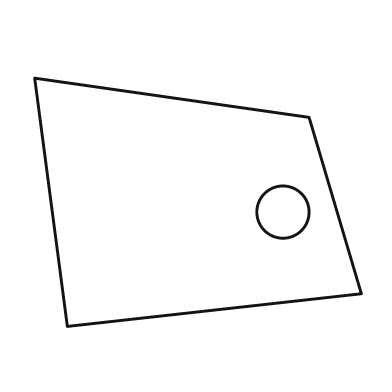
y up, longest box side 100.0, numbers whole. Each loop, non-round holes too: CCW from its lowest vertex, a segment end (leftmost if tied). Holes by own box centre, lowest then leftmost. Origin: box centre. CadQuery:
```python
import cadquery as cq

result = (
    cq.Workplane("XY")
    .moveTo(-40.0, -38.0)
    .lineTo(50.0, -28.0)
    .lineTo(34.0, 26.0)
    .lineTo(-50.0, 38.0)
    .close()
    .moveTo(26.0, -3.0)
    .circle(8.0)
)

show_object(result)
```